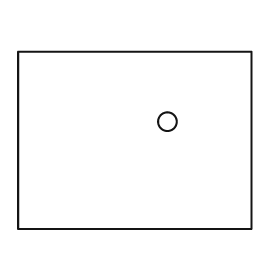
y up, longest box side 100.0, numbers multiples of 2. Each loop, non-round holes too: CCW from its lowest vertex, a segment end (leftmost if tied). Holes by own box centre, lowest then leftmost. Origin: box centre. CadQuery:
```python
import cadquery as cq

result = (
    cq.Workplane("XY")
    .moveTo(-50.0, -38.0)
    .lineTo(50.0, -38.0)
    .lineTo(50.0, 38.0)
    .lineTo(-50.0, 38.0)
    .close()
    .moveTo(14.0, 8.0)
    .circle(4.0)
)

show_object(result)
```